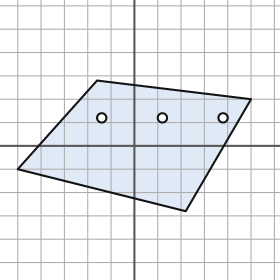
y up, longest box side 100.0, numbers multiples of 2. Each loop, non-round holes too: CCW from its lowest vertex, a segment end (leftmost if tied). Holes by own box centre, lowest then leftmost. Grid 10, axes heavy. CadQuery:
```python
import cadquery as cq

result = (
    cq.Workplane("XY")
    .moveTo(22.0, -28.0)
    .lineTo(50.0, 20.0)
    .lineTo(-16.0, 28.0)
    .lineTo(-50.0, -10.0)
    .close()
    .moveTo(-14.0, 12.0)
    .circle(2.0)
    .moveTo(12.0, 12.0)
    .circle(2.0)
    .moveTo(38.0, 12.0)
    .circle(2.0)
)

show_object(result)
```